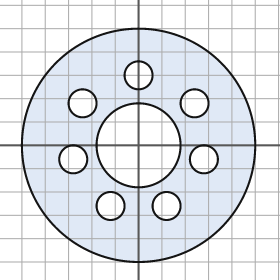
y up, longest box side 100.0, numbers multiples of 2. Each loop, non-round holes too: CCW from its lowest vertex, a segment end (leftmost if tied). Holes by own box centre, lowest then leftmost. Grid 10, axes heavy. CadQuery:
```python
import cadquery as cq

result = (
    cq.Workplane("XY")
    .moveTo(0.0, 0.0)
    .circle(50.0)
    .moveTo(-12.0, -26.0)
    .circle(6.0)
    .moveTo(12.0, -26.0)
    .circle(6.0)
    .moveTo(-28.0, -6.0)
    .circle(6.0)
    .moveTo(28.0, -6.0)
    .circle(6.0)
    .moveTo(0.0, 0.0)
    .circle(18.0)
    .moveTo(-24.0, 18.0)
    .circle(6.0)
    .moveTo(24.0, 18.0)
    .circle(6.0)
    .moveTo(0.0, 30.0)
    .circle(6.0)
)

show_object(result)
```